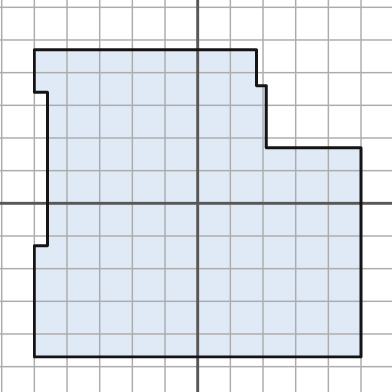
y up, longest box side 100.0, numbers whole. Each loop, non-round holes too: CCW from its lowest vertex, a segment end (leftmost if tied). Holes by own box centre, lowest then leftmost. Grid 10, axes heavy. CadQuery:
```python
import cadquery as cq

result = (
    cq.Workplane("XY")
    .moveTo(-50.0, -47.0)
    .lineTo(50.0, -47.0)
    .lineTo(50.0, 17.0)
    .lineTo(21.0, 17.0)
    .lineTo(21.0, 36.0)
    .lineTo(18.0, 36.0)
    .lineTo(18.0, 47.0)
    .lineTo(-50.0, 47.0)
    .lineTo(-50.0, 34.0)
    .lineTo(-46.0, 34.0)
    .lineTo(-46.0, -13.0)
    .lineTo(-50.0, -13.0)
    .close()
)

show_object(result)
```